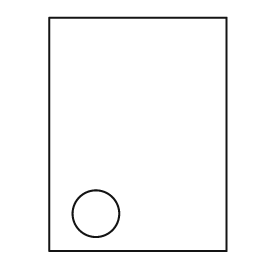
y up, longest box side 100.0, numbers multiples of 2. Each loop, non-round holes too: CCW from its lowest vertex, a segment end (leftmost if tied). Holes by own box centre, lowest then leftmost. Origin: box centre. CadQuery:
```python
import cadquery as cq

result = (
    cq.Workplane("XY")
    .moveTo(-38.0, -50.0)
    .lineTo(38.0, -50.0)
    .lineTo(38.0, 50.0)
    .lineTo(-38.0, 50.0)
    .close()
    .moveTo(-18.0, -34.0)
    .circle(10.0)
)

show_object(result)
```